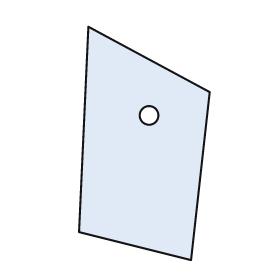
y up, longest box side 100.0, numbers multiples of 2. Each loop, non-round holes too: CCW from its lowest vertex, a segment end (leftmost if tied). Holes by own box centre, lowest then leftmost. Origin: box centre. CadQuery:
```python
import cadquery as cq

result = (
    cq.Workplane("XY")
    .moveTo(20.0, -50.0)
    .lineTo(28.0, 22.0)
    .lineTo(-24.0, 50.0)
    .lineTo(-28.0, -38.0)
    .close()
    .moveTo(2.0, 12.0)
    .circle(4.0)
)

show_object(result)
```